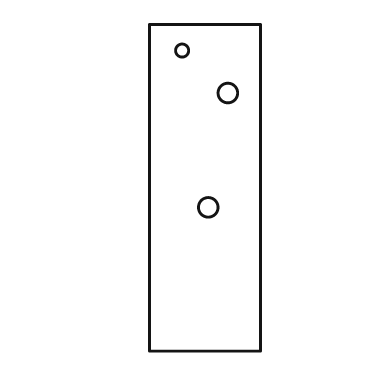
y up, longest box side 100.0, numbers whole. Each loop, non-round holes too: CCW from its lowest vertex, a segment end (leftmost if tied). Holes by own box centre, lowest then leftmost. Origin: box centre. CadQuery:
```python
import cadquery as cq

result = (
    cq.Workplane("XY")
    .moveTo(-17.0, -50.0)
    .lineTo(17.0, -50.0)
    .lineTo(17.0, 50.0)
    .lineTo(-17.0, 50.0)
    .close()
    .moveTo(1.0, -6.0)
    .circle(3.0)
    .moveTo(7.0, 29.0)
    .circle(3.0)
    .moveTo(-7.0, 42.0)
    .circle(2.0)
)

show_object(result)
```